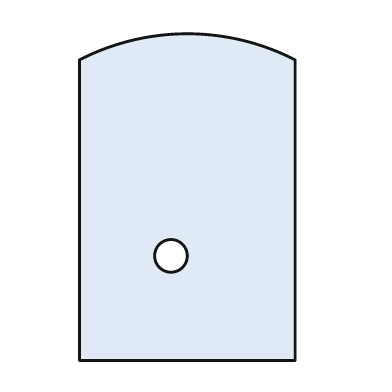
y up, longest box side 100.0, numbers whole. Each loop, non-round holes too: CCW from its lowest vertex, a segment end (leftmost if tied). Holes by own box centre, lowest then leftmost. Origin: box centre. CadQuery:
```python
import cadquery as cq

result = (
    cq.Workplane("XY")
    .moveTo(-33.0, -50.0)
    .lineTo(33.0, -50.0)
    .lineTo(33.0, 42.0)
    .threePointArc((0.0, 50.0), (-33.0, 42.0))
    .close()
    .moveTo(-5.0, -18.0)
    .circle(5.0)
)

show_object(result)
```